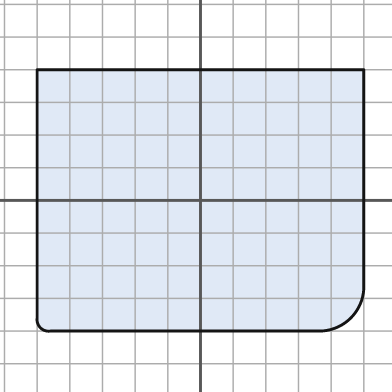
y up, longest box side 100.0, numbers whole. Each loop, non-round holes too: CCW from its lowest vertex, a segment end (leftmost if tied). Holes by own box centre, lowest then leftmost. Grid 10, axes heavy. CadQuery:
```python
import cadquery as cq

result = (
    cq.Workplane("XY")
    .moveTo(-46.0, -40.0)
    .lineTo(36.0, -40.0)
    .threePointArc((46.0, -36.0), (50.0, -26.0))
    .lineTo(50.0, 40.0)
    .lineTo(-50.0, 40.0)
    .lineTo(-50.0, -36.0)
    .threePointArc((-49.0, -39.0), (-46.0, -40.0))
    .close()
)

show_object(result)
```